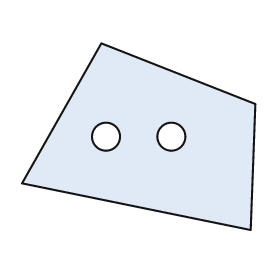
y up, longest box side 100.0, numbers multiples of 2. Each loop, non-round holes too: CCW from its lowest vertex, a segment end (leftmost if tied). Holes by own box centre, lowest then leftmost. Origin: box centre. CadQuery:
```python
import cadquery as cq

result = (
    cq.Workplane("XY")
    .moveTo(48.0, -40.0)
    .lineTo(50.0, 14.0)
    .lineTo(-16.0, 40.0)
    .lineTo(-50.0, -20.0)
    .close()
    .moveTo(-14.0, 0.0)
    .circle(6.0)
    .moveTo(14.0, 0.0)
    .circle(6.0)
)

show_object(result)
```